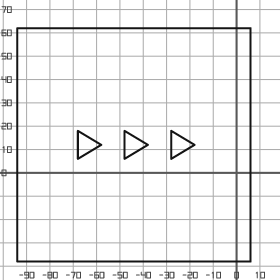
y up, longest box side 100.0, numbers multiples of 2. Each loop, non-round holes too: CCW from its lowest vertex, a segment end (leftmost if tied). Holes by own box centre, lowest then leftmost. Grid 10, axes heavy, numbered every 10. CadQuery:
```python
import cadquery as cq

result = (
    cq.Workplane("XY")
    .moveTo(-94.0, -38.0)
    .lineTo(6.0, -38.0)
    .lineTo(6.0, 62.0)
    .lineTo(-94.0, 62.0)
    .close()
    .moveTo(-68.0, 6.0)
    .lineTo(-58.0, 12.0)
    .lineTo(-68.0, 18.0)
    .close()
    .moveTo(-48.0, 6.0)
    .lineTo(-38.0, 12.0)
    .lineTo(-48.0, 18.0)
    .close()
    .moveTo(-28.0, 6.0)
    .lineTo(-18.0, 12.0)
    .lineTo(-28.0, 18.0)
    .close()
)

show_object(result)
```